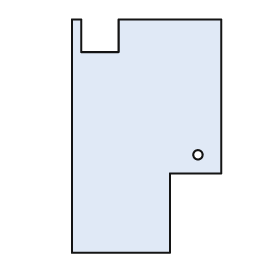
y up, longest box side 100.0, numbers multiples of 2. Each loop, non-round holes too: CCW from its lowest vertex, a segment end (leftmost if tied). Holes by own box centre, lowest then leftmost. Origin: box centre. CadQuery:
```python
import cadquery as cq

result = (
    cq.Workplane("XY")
    .moveTo(-32.0, -50.0)
    .lineTo(10.0, -50.0)
    .lineTo(10.0, -16.0)
    .lineTo(32.0, -16.0)
    .lineTo(32.0, 50.0)
    .lineTo(-12.0, 50.0)
    .lineTo(-12.0, 36.0)
    .lineTo(-28.0, 36.0)
    .lineTo(-28.0, 50.0)
    .lineTo(-32.0, 50.0)
    .close()
    .moveTo(22.0, -8.0)
    .circle(2.0)
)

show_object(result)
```